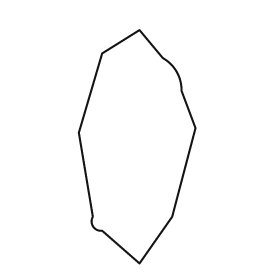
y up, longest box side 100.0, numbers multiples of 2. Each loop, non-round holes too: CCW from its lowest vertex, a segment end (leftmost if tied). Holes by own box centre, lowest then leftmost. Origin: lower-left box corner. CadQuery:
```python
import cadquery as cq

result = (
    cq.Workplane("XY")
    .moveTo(26.0, 0.0)
    .lineTo(40.0, 20.0)
    .lineTo(50.0, 58.0)
    .lineTo(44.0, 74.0)
    .threePointArc((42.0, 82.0), (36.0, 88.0))
    .lineTo(26.0, 100.0)
    .lineTo(10.0, 90.0)
    .lineTo(0.0, 56.0)
    .lineTo(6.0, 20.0)
    .threePointArc((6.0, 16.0), (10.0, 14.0))
    .close()
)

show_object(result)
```